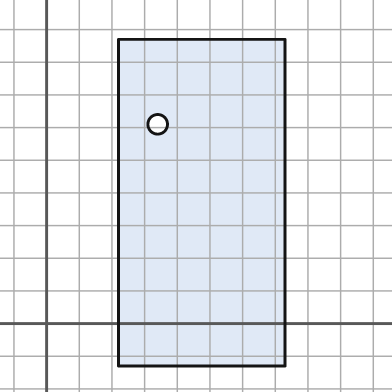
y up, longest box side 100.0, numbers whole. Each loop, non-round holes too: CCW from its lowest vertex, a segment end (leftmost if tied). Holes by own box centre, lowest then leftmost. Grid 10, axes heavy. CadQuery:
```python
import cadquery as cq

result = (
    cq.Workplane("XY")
    .moveTo(22.0, -13.0)
    .lineTo(73.0, -13.0)
    .lineTo(73.0, 87.0)
    .lineTo(22.0, 87.0)
    .close()
    .moveTo(34.0, 61.0)
    .circle(3.0)
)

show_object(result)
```